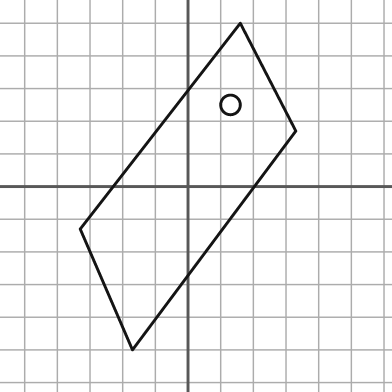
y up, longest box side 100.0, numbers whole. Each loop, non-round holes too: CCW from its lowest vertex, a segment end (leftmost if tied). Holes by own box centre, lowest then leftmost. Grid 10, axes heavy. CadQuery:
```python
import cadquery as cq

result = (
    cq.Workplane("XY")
    .moveTo(-17.0, -50.0)
    .lineTo(33.0, 17.0)
    .lineTo(16.0, 50.0)
    .lineTo(-33.0, -13.0)
    .close()
    .moveTo(13.0, 25.0)
    .circle(3.0)
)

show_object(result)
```